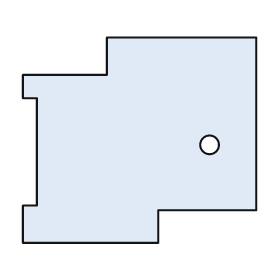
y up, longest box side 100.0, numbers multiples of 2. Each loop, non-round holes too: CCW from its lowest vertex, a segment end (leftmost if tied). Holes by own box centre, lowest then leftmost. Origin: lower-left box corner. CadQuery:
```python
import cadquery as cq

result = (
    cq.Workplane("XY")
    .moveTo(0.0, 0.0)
    .lineTo(58.0, 0.0)
    .lineTo(58.0, 14.0)
    .lineTo(100.0, 14.0)
    .lineTo(100.0, 88.0)
    .lineTo(36.0, 88.0)
    .lineTo(36.0, 72.0)
    .lineTo(0.0, 72.0)
    .lineTo(0.0, 62.0)
    .lineTo(6.0, 62.0)
    .lineTo(6.0, 16.0)
    .lineTo(0.0, 16.0)
    .close()
    .moveTo(80.0, 42.0)
    .circle(4.0)
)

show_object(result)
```